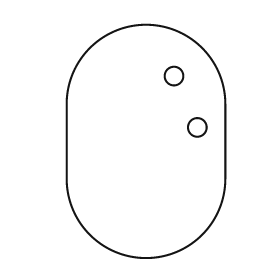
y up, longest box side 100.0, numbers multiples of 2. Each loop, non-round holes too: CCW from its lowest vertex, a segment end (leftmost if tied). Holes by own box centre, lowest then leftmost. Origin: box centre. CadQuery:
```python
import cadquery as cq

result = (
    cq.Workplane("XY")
    .moveTo(-34.0, -16.0)
    .threePointArc((0.0, -50.0), (34.0, -16.0))
    .lineTo(34.0, 16.0)
    .threePointArc((0.0, 50.0), (-34.0, 16.0))
    .close()
    .moveTo(22.0, 6.0)
    .circle(4.0)
    .moveTo(12.0, 28.0)
    .circle(4.0)
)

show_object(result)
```